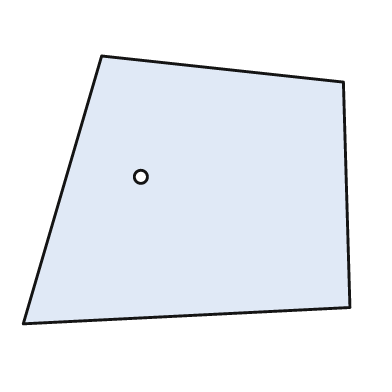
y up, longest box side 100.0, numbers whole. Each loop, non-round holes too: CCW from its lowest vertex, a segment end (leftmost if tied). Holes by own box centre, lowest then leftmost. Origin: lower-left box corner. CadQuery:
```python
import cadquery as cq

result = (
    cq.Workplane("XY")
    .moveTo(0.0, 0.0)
    .lineTo(100.0, 5.0)
    .lineTo(98.0, 74.0)
    .lineTo(24.0, 82.0)
    .close()
    .moveTo(36.0, 45.0)
    .circle(2.0)
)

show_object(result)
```